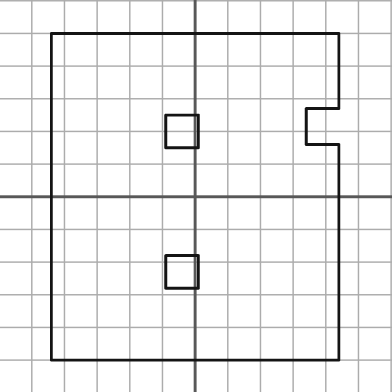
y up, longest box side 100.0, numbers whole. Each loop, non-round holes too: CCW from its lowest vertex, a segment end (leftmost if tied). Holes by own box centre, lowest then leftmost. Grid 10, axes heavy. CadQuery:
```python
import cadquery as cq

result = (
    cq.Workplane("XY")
    .moveTo(-44.0, -50.0)
    .lineTo(44.0, -50.0)
    .lineTo(44.0, 16.0)
    .lineTo(34.0, 16.0)
    .lineTo(34.0, 27.0)
    .lineTo(44.0, 27.0)
    .lineTo(44.0, 50.0)
    .lineTo(-44.0, 50.0)
    .close()
    .moveTo(-9.0, -28.0)
    .lineTo(1.0, -28.0)
    .lineTo(1.0, -18.0)
    .lineTo(-9.0, -18.0)
    .close()
    .moveTo(-9.0, 15.0)
    .lineTo(1.0, 15.0)
    .lineTo(1.0, 25.0)
    .lineTo(-9.0, 25.0)
    .close()
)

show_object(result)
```